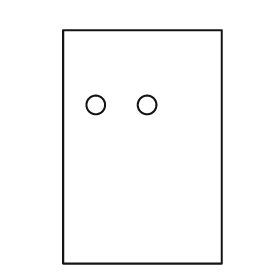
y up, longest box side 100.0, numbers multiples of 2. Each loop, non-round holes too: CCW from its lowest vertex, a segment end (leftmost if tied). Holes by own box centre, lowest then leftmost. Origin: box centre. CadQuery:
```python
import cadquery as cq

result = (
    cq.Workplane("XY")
    .moveTo(-34.0, -50.0)
    .lineTo(34.0, -50.0)
    .lineTo(34.0, 50.0)
    .lineTo(-34.0, 50.0)
    .close()
    .moveTo(-20.0, 18.0)
    .circle(4.0)
    .moveTo(2.0, 18.0)
    .circle(4.0)
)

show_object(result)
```